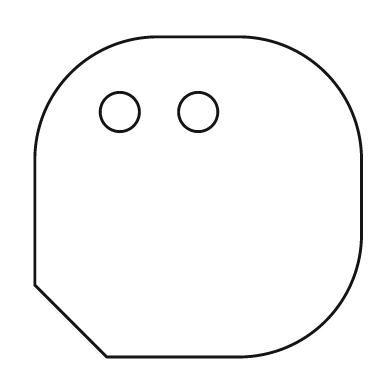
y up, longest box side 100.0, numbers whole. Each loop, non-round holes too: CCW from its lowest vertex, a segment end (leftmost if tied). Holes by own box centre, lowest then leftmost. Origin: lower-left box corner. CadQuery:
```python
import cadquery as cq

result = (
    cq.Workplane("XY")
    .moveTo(22.0, 0.0)
    .lineTo(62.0, 0.0)
    .threePointArc((89.0, 11.0), (100.0, 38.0))
    .lineTo(100.0, 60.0)
    .threePointArc((89.0, 87.0), (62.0, 98.0))
    .lineTo(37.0, 98.0)
    .threePointArc((11.0, 87.0), (0.0, 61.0))
    .lineTo(0.0, 22.0)
    .close()
    .moveTo(26.0, 75.0)
    .circle(6.0)
    .moveTo(50.0, 75.0)
    .circle(6.0)
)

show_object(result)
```